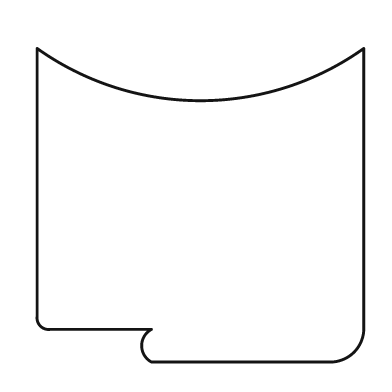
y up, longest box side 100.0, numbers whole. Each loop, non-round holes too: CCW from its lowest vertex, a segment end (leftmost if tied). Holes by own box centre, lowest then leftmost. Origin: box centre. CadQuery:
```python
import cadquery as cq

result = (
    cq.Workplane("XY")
    .moveTo(-15.0, -48.0)
    .lineTo(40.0, -48.0)
    .threePointArc((47.0, -45.0), (50.0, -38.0))
    .lineTo(50.0, 48.0)
    .threePointArc((0.0, 32.0), (-50.0, 48.0))
    .lineTo(-50.0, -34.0)
    .threePointArc((-49.0, -37.0), (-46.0, -38.0))
    .lineTo(-15.0, -38.0)
    .threePointArc((-18.0, -43.0), (-15.0, -48.0))
    .close()
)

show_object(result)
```